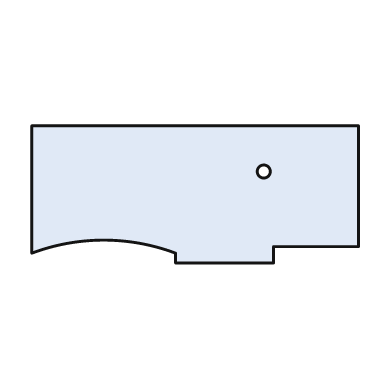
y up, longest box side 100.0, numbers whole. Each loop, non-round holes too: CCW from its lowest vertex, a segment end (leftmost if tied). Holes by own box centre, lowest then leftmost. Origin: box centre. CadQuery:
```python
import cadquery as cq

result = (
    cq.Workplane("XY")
    .moveTo(-6.0, -21.0)
    .lineTo(24.0, -21.0)
    .lineTo(24.0, -16.0)
    .lineTo(50.0, -16.0)
    .lineTo(50.0, 21.0)
    .lineTo(-50.0, 21.0)
    .lineTo(-50.0, -18.0)
    .threePointArc((-28.0, -14.0), (-6.0, -18.0))
    .close()
    .moveTo(21.0, 7.0)
    .circle(2.0)
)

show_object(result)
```